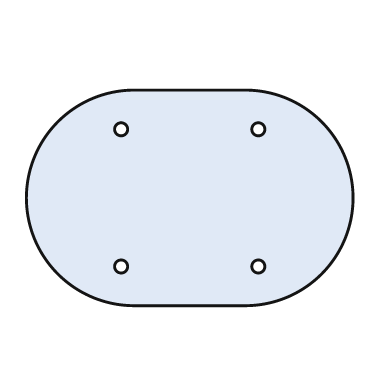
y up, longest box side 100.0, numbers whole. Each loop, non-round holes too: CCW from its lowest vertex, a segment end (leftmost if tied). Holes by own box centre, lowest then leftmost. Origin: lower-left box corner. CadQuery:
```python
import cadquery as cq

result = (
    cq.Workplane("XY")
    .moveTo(33.0, 0.0)
    .lineTo(67.0, 0.0)
    .threePointArc((100.0, 33.0), (67.0, 66.0))
    .lineTo(33.0, 66.0)
    .threePointArc((0.0, 33.0), (33.0, 0.0))
    .close()
    .moveTo(29.0, 12.0)
    .circle(2.0)
    .moveTo(71.0, 12.0)
    .circle(2.0)
    .moveTo(29.0, 54.0)
    .circle(2.0)
    .moveTo(71.0, 54.0)
    .circle(2.0)
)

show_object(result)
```